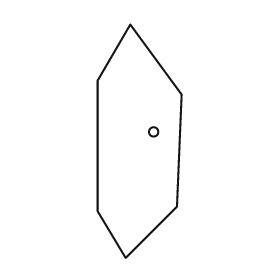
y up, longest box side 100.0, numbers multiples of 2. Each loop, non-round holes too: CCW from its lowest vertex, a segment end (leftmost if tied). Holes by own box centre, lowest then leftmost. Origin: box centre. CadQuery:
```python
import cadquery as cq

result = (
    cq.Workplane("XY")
    .moveTo(-6.0, -50.0)
    .lineTo(16.0, -28.0)
    .lineTo(18.0, 20.0)
    .lineTo(-4.0, 50.0)
    .lineTo(-18.0, 26.0)
    .lineTo(-18.0, -30.0)
    .close()
    .moveTo(6.0, 4.0)
    .circle(2.0)
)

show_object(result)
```